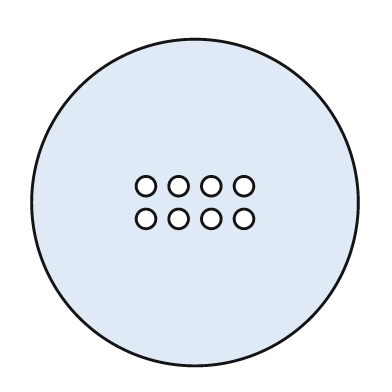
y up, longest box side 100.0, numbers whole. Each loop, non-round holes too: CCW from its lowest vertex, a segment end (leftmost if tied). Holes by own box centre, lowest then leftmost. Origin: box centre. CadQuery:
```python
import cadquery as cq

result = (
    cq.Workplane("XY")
    .moveTo(0.0, 0.0)
    .circle(50.0)
    .moveTo(-15.0, -5.0)
    .circle(3.0)
    .moveTo(-5.0, -5.0)
    .circle(3.0)
    .moveTo(5.0, -5.0)
    .circle(3.0)
    .moveTo(15.0, -5.0)
    .circle(3.0)
    .moveTo(-15.0, 5.0)
    .circle(3.0)
    .moveTo(-5.0, 5.0)
    .circle(3.0)
    .moveTo(5.0, 5.0)
    .circle(3.0)
    .moveTo(15.0, 5.0)
    .circle(3.0)
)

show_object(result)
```